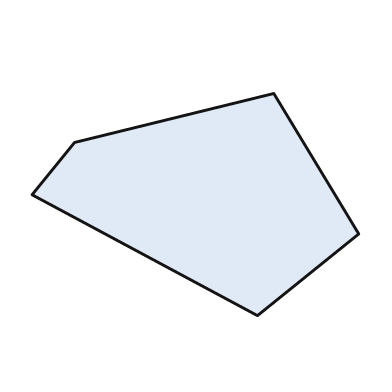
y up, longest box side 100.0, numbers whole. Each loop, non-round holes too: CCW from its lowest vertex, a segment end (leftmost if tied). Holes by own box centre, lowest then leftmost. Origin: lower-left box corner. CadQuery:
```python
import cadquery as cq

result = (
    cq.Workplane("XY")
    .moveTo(69.0, 0.0)
    .lineTo(100.0, 25.0)
    .lineTo(74.0, 68.0)
    .lineTo(13.0, 53.0)
    .lineTo(0.0, 37.0)
    .close()
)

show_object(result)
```